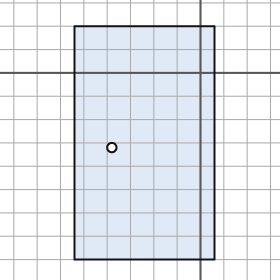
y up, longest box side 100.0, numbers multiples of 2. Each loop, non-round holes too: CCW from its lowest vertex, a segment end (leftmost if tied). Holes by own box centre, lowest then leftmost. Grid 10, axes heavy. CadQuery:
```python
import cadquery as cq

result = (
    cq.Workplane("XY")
    .moveTo(-54.0, -80.0)
    .lineTo(6.0, -80.0)
    .lineTo(6.0, 20.0)
    .lineTo(-54.0, 20.0)
    .close()
    .moveTo(-38.0, -32.0)
    .circle(2.0)
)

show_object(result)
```